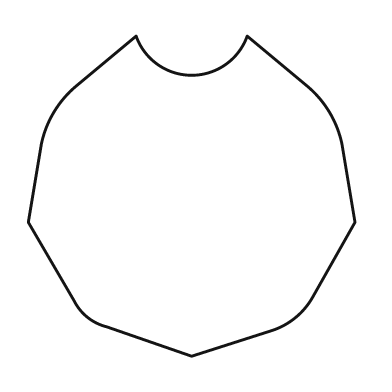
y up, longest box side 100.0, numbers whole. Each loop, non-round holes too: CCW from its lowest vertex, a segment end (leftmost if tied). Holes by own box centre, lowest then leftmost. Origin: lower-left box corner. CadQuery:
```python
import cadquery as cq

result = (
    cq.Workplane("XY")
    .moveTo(50.0, 0.0)
    .lineTo(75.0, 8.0)
    .threePointArc((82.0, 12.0), (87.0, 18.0))
    .lineTo(100.0, 41.0)
    .lineTo(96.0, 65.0)
    .threePointArc((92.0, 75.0), (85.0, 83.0))
    .lineTo(67.0, 98.0)
    .threePointArc((50.0, 86.0), (33.0, 98.0))
    .lineTo(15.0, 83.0)
    .threePointArc((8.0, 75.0), (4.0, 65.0))
    .lineTo(0.0, 41.0)
    .lineTo(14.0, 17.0)
    .threePointArc((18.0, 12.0), (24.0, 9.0))
    .close()
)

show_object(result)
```